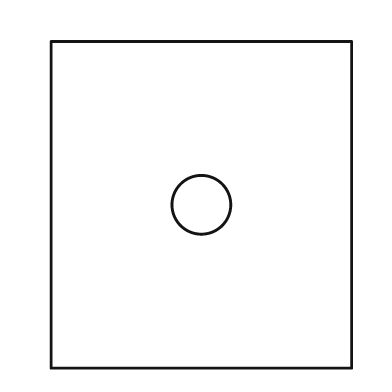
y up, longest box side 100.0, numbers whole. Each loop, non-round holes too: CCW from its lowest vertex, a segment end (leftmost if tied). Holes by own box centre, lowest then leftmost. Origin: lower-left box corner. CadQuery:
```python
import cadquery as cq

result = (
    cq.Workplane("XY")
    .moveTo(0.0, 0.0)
    .lineTo(92.0, 0.0)
    .lineTo(92.0, 100.0)
    .lineTo(0.0, 100.0)
    .close()
    .moveTo(46.0, 50.0)
    .circle(9.0)
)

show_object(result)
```